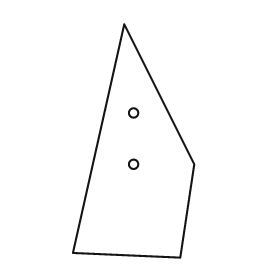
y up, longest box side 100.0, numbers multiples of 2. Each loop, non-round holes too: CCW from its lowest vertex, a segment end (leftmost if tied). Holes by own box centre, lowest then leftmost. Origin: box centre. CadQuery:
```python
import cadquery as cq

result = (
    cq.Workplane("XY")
    .moveTo(20.0, -50.0)
    .lineTo(26.0, -10.0)
    .lineTo(-4.0, 50.0)
    .lineTo(-26.0, -48.0)
    .close()
    .moveTo(0.0, -10.0)
    .circle(2.0)
    .moveTo(0.0, 12.0)
    .circle(2.0)
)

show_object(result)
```